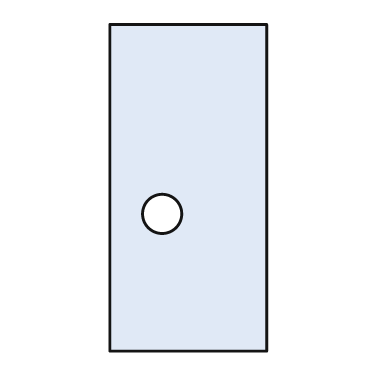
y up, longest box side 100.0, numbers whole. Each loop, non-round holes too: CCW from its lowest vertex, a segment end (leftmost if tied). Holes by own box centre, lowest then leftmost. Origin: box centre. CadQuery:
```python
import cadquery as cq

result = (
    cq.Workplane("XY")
    .moveTo(-24.0, -50.0)
    .lineTo(24.0, -50.0)
    .lineTo(24.0, 50.0)
    .lineTo(-24.0, 50.0)
    .close()
    .moveTo(-8.0, -8.0)
    .circle(6.0)
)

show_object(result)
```